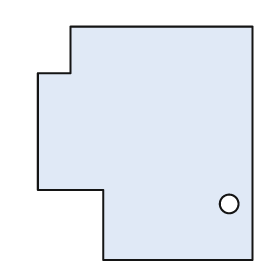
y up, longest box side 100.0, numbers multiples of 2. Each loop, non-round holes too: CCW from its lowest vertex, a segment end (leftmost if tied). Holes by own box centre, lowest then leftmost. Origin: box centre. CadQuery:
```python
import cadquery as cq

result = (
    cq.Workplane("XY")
    .moveTo(-18.0, -50.0)
    .lineTo(46.0, -50.0)
    .lineTo(46.0, 50.0)
    .lineTo(-32.0, 50.0)
    .lineTo(-32.0, 30.0)
    .lineTo(-46.0, 30.0)
    .lineTo(-46.0, -20.0)
    .lineTo(-18.0, -20.0)
    .close()
    .moveTo(36.0, -26.0)
    .circle(4.0)
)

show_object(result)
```